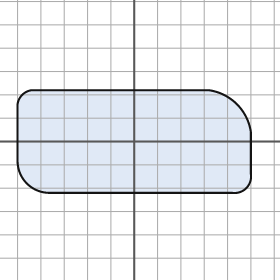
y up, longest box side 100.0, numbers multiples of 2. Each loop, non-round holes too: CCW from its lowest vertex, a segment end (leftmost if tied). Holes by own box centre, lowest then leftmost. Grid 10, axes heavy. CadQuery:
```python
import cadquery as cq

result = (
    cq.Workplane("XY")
    .moveTo(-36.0, -22.0)
    .lineTo(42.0, -22.0)
    .threePointArc((48.0, -20.0), (50.0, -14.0))
    .lineTo(50.0, 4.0)
    .threePointArc((44.0, 16.0), (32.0, 22.0))
    .lineTo(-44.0, 22.0)
    .threePointArc((-48.0, 20.0), (-50.0, 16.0))
    .lineTo(-50.0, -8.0)
    .threePointArc((-46.0, -18.0), (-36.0, -22.0))
    .close()
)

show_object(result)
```